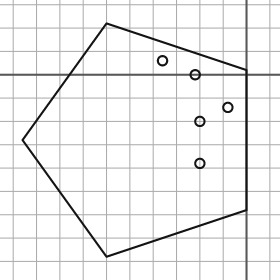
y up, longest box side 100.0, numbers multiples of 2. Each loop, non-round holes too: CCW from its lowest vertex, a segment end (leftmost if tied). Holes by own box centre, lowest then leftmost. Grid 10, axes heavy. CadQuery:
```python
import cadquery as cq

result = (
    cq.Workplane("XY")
    .moveTo(-60.0, -78.0)
    .lineTo(0.0, -58.0)
    .lineTo(0.0, 2.0)
    .lineTo(-60.0, 22.0)
    .lineTo(-96.0, -28.0)
    .close()
    .moveTo(-20.0, -38.0)
    .circle(2.0)
    .moveTo(-20.0, -20.0)
    .circle(2.0)
    .moveTo(-8.0, -14.0)
    .circle(2.0)
    .moveTo(-22.0, 0.0)
    .circle(2.0)
    .moveTo(-36.0, 6.0)
    .circle(2.0)
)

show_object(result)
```